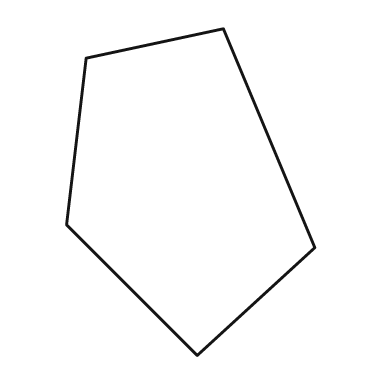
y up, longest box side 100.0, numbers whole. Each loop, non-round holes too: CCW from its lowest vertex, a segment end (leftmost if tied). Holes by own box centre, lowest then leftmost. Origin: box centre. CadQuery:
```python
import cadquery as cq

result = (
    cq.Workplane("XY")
    .moveTo(2.0, -50.0)
    .lineTo(38.0, -17.0)
    .lineTo(10.0, 50.0)
    .lineTo(-32.0, 41.0)
    .lineTo(-38.0, -10.0)
    .close()
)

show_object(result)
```